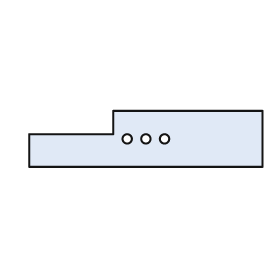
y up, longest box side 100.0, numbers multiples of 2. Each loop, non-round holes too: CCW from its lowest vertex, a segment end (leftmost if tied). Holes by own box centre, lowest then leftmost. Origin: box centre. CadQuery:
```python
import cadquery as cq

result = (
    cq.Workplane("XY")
    .moveTo(-50.0, -12.0)
    .lineTo(50.0, -12.0)
    .lineTo(50.0, 12.0)
    .lineTo(-14.0, 12.0)
    .lineTo(-14.0, 2.0)
    .lineTo(-50.0, 2.0)
    .close()
    .moveTo(-8.0, 0.0)
    .circle(2.0)
    .moveTo(0.0, 0.0)
    .circle(2.0)
    .moveTo(8.0, 0.0)
    .circle(2.0)
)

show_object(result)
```